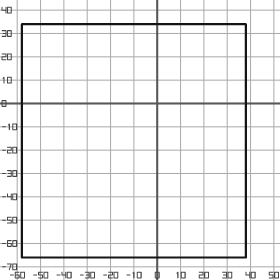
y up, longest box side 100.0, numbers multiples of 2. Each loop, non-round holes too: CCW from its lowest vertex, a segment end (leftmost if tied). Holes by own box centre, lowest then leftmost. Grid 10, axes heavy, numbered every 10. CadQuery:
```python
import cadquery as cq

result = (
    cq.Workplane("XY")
    .moveTo(-58.0, -66.0)
    .lineTo(38.0, -66.0)
    .lineTo(38.0, 34.0)
    .lineTo(-58.0, 34.0)
    .close()
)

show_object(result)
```